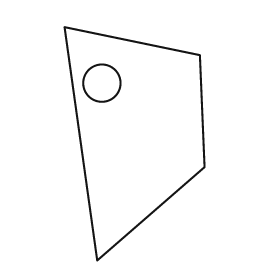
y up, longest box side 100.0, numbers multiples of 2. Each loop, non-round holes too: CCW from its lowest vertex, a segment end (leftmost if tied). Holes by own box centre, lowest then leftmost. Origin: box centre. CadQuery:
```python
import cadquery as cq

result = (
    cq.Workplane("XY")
    .moveTo(-16.0, -50.0)
    .lineTo(30.0, -10.0)
    .lineTo(28.0, 38.0)
    .lineTo(-30.0, 50.0)
    .close()
    .moveTo(-14.0, 26.0)
    .circle(8.0)
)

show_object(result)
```